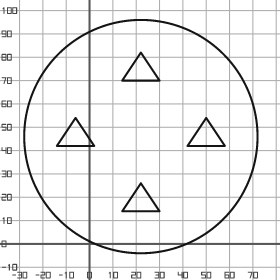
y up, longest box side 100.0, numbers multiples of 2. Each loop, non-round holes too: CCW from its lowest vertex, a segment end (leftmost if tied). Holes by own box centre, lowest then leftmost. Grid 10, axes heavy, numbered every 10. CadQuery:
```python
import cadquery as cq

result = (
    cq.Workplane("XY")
    .moveTo(22.0, 46.0)
    .circle(50.0)
    .moveTo(14.0, 14.0)
    .lineTo(30.0, 14.0)
    .lineTo(22.0, 26.0)
    .close()
    .moveTo(-14.0, 42.0)
    .lineTo(2.0, 42.0)
    .lineTo(-6.0, 54.0)
    .close()
    .moveTo(42.0, 42.0)
    .lineTo(58.0, 42.0)
    .lineTo(50.0, 54.0)
    .close()
    .moveTo(14.0, 70.0)
    .lineTo(30.0, 70.0)
    .lineTo(22.0, 82.0)
    .close()
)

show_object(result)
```